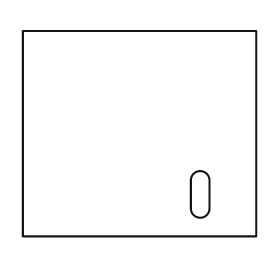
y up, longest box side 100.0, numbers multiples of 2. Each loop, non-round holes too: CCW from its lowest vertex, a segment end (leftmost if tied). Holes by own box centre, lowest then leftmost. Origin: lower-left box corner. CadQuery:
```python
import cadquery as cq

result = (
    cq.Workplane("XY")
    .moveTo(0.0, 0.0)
    .lineTo(100.0, 0.0)
    .lineTo(100.0, 88.0)
    .lineTo(0.0, 88.0)
    .close()
    .moveTo(72.0, 12.0)
    .threePointArc((76.0, 8.0), (80.0, 12.0))
    .lineTo(80.0, 24.0)
    .threePointArc((76.0, 28.0), (72.0, 24.0))
    .close()
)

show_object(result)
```